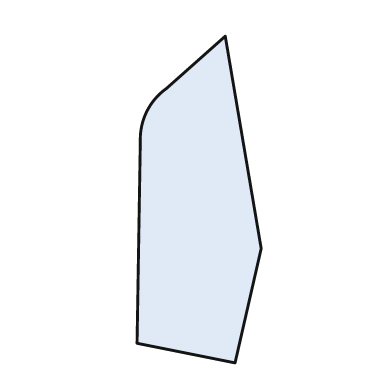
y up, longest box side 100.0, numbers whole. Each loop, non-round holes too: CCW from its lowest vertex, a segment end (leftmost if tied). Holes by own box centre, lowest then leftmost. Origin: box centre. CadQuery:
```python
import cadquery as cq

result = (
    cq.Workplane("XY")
    .moveTo(11.0, -50.0)
    .lineTo(19.0, -15.0)
    .lineTo(8.0, 50.0)
    .lineTo(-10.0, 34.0)
    .threePointArc((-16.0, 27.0), (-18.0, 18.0))
    .lineTo(-19.0, -44.0)
    .close()
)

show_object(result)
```